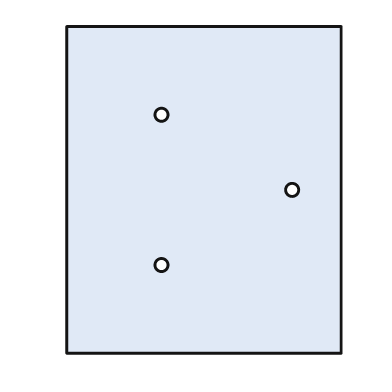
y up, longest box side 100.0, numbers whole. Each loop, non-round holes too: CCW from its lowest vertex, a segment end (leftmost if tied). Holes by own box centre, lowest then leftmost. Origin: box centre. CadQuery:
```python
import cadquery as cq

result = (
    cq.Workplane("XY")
    .moveTo(-42.0, -50.0)
    .lineTo(42.0, -50.0)
    .lineTo(42.0, 50.0)
    .lineTo(-42.0, 50.0)
    .close()
    .moveTo(-13.0, -23.0)
    .circle(2.0)
    .moveTo(27.0, 0.0)
    .circle(2.0)
    .moveTo(-13.0, 23.0)
    .circle(2.0)
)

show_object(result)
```